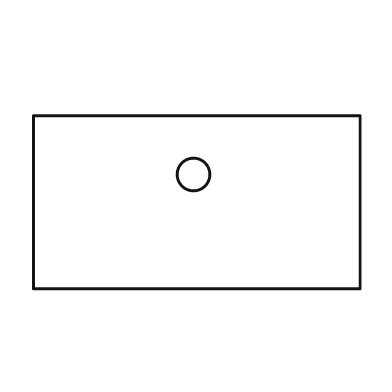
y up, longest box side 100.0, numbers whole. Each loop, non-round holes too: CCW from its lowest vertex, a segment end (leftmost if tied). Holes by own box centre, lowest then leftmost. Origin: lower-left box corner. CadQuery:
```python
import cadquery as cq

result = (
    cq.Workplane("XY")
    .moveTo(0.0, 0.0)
    .lineTo(100.0, 0.0)
    .lineTo(100.0, 53.0)
    .lineTo(0.0, 53.0)
    .close()
    .moveTo(49.0, 35.0)
    .circle(5.0)
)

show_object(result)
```